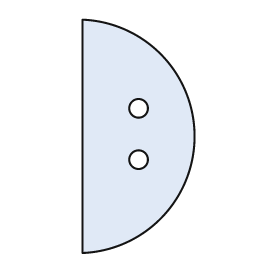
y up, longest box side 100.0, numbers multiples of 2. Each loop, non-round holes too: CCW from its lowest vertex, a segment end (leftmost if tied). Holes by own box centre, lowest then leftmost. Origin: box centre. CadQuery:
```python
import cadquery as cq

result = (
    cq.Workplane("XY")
    .moveTo(-24.0, -50.0)
    .threePointArc((24.0, 0.0), (-24.0, 50.0))
    .close()
    .moveTo(0.0, -10.0)
    .circle(4.0)
    .moveTo(0.0, 12.0)
    .circle(4.0)
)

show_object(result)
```